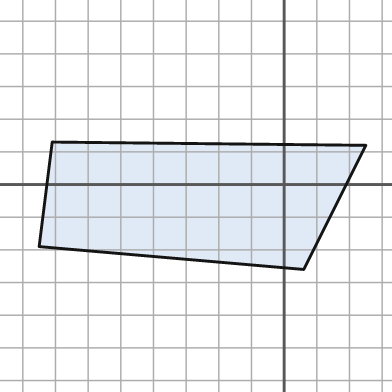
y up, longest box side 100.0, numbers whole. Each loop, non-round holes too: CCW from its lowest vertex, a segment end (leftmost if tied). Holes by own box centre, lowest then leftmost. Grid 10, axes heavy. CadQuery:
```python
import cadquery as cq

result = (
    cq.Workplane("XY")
    .moveTo(6.0, -26.0)
    .lineTo(25.0, 12.0)
    .lineTo(-71.0, 13.0)
    .lineTo(-75.0, -19.0)
    .close()
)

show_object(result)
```